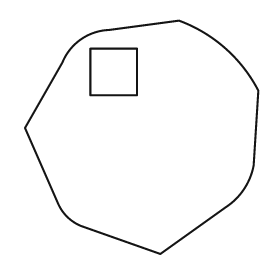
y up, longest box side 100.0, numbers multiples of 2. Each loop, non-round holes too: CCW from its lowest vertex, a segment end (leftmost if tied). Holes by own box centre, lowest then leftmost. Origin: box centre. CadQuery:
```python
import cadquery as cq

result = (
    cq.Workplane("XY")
    .moveTo(8.0, -50.0)
    .lineTo(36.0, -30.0)
    .threePointArc((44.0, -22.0), (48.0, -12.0))
    .lineTo(50.0, 20.0)
    .threePointArc((36.0, 38.0), (16.0, 50.0))
    .lineTo(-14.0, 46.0)
    .threePointArc((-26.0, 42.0), (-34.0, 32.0))
    .lineTo(-50.0, 4.0)
    .lineTo(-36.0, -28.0)
    .threePointArc((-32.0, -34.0), (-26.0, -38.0))
    .close()
    .moveTo(-22.0, 18.0)
    .lineTo(-2.0, 18.0)
    .lineTo(-2.0, 38.0)
    .lineTo(-22.0, 38.0)
    .close()
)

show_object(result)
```